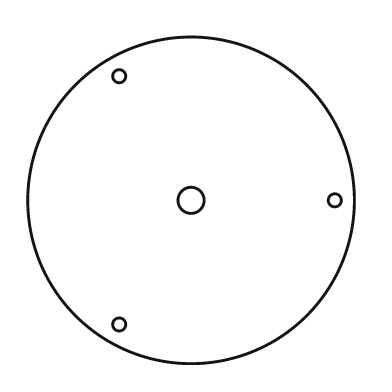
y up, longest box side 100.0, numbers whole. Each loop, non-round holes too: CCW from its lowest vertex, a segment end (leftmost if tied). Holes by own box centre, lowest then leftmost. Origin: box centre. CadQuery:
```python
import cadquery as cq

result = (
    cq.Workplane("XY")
    .moveTo(0.0, 0.0)
    .circle(50.0)
    .moveTo(-22.0, -38.0)
    .circle(2.0)
    .moveTo(0.0, 0.0)
    .circle(4.0)
    .moveTo(44.0, 0.0)
    .circle(2.0)
    .moveTo(-22.0, 38.0)
    .circle(2.0)
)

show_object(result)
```